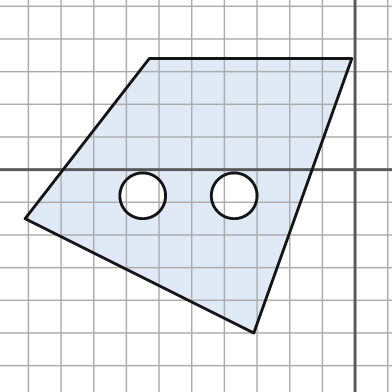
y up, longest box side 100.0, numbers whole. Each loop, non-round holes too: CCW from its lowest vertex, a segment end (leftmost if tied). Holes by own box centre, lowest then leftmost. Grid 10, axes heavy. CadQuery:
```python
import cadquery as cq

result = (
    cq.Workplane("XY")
    .moveTo(-31.0, -50.0)
    .lineTo(-1.0, 34.0)
    .lineTo(-63.0, 34.0)
    .lineTo(-101.0, -15.0)
    .close()
    .moveTo(-65.0, -8.0)
    .circle(7.0)
    .moveTo(-37.0, -8.0)
    .circle(7.0)
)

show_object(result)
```